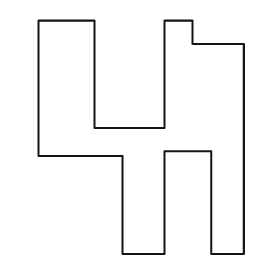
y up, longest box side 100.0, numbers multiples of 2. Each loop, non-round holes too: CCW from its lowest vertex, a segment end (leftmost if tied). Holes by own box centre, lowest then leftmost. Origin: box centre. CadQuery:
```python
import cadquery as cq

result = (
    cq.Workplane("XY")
    .moveTo(-8.0, -50.0)
    .lineTo(10.0, -50.0)
    .lineTo(10.0, -6.0)
    .lineTo(30.0, -6.0)
    .lineTo(30.0, -50.0)
    .lineTo(44.0, -50.0)
    .lineTo(44.0, 40.0)
    .lineTo(22.0, 40.0)
    .lineTo(22.0, 50.0)
    .lineTo(10.0, 50.0)
    .lineTo(10.0, 4.0)
    .lineTo(-20.0, 4.0)
    .lineTo(-20.0, 50.0)
    .lineTo(-44.0, 50.0)
    .lineTo(-44.0, -8.0)
    .lineTo(-8.0, -8.0)
    .close()
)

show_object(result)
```